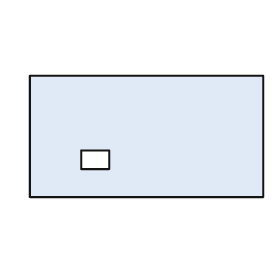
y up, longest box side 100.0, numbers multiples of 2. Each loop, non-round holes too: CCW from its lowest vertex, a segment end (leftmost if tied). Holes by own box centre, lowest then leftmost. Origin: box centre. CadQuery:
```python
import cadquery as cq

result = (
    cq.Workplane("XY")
    .moveTo(-50.0, -26.0)
    .lineTo(50.0, -26.0)
    .lineTo(50.0, 26.0)
    .lineTo(-50.0, 26.0)
    .close()
    .moveTo(-28.0, -14.0)
    .lineTo(-16.0, -14.0)
    .lineTo(-16.0, -6.0)
    .lineTo(-28.0, -6.0)
    .close()
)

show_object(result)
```